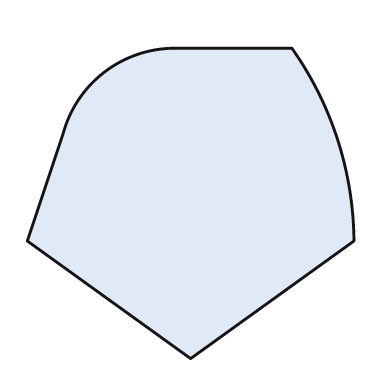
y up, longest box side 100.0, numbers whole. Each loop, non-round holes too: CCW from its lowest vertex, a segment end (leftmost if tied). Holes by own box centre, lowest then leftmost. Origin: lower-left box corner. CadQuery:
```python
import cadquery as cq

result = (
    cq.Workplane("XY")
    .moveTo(50.0, 0.0)
    .lineTo(100.0, 36.0)
    .threePointArc((95.0, 67.0), (81.0, 95.0))
    .lineTo(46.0, 95.0)
    .threePointArc((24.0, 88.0), (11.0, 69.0))
    .lineTo(0.0, 36.0)
    .close()
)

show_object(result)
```